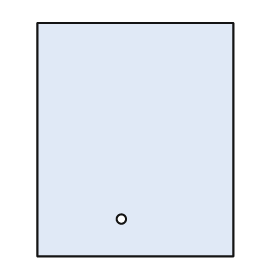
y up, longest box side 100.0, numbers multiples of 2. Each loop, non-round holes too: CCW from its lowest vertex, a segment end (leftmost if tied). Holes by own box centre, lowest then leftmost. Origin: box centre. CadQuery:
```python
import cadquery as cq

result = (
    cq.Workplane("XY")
    .moveTo(-42.0, -50.0)
    .lineTo(42.0, -50.0)
    .lineTo(42.0, 50.0)
    .lineTo(-42.0, 50.0)
    .close()
    .moveTo(-6.0, -34.0)
    .circle(2.0)
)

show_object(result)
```